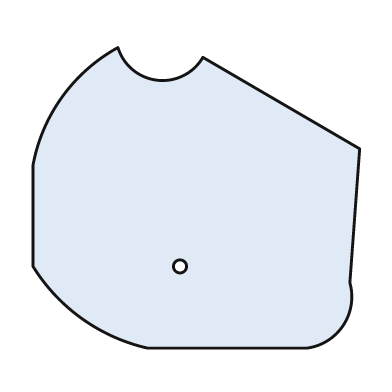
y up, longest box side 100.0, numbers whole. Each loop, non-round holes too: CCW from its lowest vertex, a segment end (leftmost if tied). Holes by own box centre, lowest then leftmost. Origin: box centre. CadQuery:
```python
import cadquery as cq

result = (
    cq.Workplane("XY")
    .moveTo(-15.0, -46.0)
    .lineTo(34.0, -46.0)
    .threePointArc((45.0, -39.0), (47.0, -26.0))
    .lineTo(50.0, 15.0)
    .lineTo(2.0, 43.0)
    .threePointArc((-12.0, 36.0), (-24.0, 46.0))
    .threePointArc((-41.0, 31.0), (-50.0, 10.0))
    .lineTo(-50.0, -21.0)
    .threePointArc((-35.0, -37.0), (-15.0, -46.0))
    .close()
    .moveTo(-5.0, -21.0)
    .circle(2.0)
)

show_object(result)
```